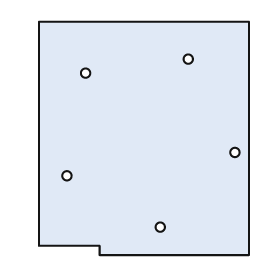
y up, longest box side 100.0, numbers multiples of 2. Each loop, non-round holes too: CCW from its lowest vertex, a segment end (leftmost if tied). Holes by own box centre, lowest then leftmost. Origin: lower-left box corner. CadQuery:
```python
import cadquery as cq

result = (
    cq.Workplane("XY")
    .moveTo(26.0, 0.0)
    .lineTo(90.0, 0.0)
    .lineTo(90.0, 100.0)
    .lineTo(0.0, 100.0)
    .lineTo(0.0, 4.0)
    .lineTo(26.0, 4.0)
    .close()
    .moveTo(52.0, 12.0)
    .circle(2.0)
    .moveTo(12.0, 34.0)
    .circle(2.0)
    .moveTo(84.0, 44.0)
    .circle(2.0)
    .moveTo(20.0, 78.0)
    .circle(2.0)
    .moveTo(64.0, 84.0)
    .circle(2.0)
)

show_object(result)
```